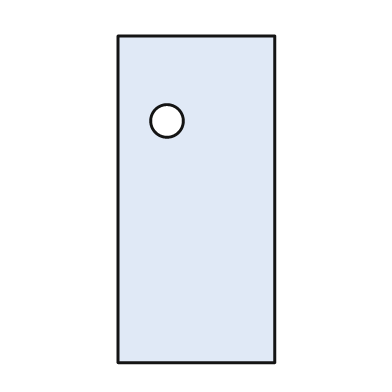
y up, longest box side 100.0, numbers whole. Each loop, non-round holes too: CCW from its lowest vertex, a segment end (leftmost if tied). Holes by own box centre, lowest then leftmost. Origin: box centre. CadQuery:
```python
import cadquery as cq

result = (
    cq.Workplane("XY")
    .moveTo(-24.0, -50.0)
    .lineTo(24.0, -50.0)
    .lineTo(24.0, 50.0)
    .lineTo(-24.0, 50.0)
    .close()
    .moveTo(-9.0, 24.0)
    .circle(5.0)
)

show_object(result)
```